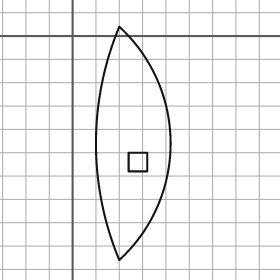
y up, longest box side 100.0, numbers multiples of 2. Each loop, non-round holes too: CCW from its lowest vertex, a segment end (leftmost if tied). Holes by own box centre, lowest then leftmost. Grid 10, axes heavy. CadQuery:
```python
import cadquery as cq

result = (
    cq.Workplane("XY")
    .moveTo(20.0, -96.0)
    .threePointArc((42.0, -46.0), (20.0, 4.0))
    .threePointArc((10.0, -46.0), (20.0, -96.0))
    .close()
    .moveTo(24.0, -58.0)
    .lineTo(32.0, -58.0)
    .lineTo(32.0, -50.0)
    .lineTo(24.0, -50.0)
    .close()
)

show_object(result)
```